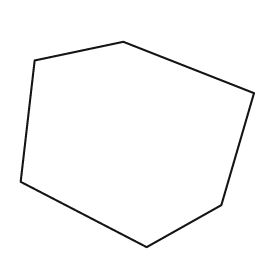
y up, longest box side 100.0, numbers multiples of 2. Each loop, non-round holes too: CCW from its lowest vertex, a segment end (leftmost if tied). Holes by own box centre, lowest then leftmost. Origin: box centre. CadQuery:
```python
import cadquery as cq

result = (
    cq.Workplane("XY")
    .moveTo(4.0, -44.0)
    .lineTo(36.0, -26.0)
    .lineTo(50.0, 22.0)
    .lineTo(-6.0, 44.0)
    .lineTo(-44.0, 36.0)
    .lineTo(-50.0, -16.0)
    .close()
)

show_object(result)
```